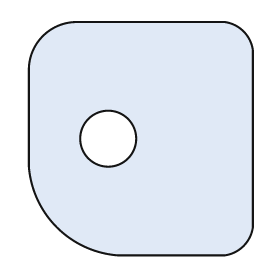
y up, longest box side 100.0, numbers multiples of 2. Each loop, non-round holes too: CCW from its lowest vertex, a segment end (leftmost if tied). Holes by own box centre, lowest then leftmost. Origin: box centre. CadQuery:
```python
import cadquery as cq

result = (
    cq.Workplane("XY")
    .moveTo(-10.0, -50.0)
    .lineTo(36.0, -50.0)
    .threePointArc((44.0, -46.0), (48.0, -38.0))
    .lineTo(48.0, 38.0)
    .threePointArc((44.0, 46.0), (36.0, 50.0))
    .lineTo(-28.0, 50.0)
    .threePointArc((-42.0, 44.0), (-48.0, 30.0))
    .lineTo(-48.0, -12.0)
    .threePointArc((-36.0, -38.0), (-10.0, -50.0))
    .close()
    .moveTo(-14.0, 0.0)
    .circle(12.0)
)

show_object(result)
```